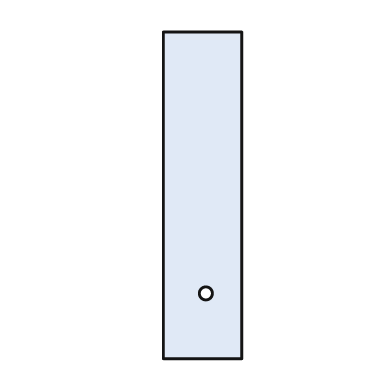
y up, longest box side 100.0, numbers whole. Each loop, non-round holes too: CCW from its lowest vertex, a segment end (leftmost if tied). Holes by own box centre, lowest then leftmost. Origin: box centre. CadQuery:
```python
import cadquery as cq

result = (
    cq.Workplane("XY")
    .moveTo(-12.0, -50.0)
    .lineTo(12.0, -50.0)
    .lineTo(12.0, 50.0)
    .lineTo(-12.0, 50.0)
    .close()
    .moveTo(1.0, -30.0)
    .circle(2.0)
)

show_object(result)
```